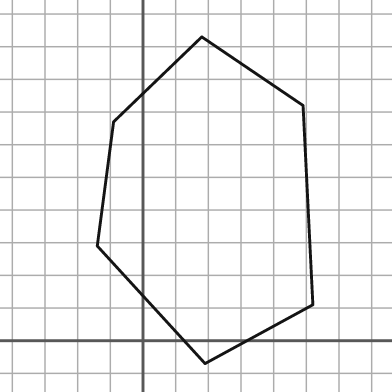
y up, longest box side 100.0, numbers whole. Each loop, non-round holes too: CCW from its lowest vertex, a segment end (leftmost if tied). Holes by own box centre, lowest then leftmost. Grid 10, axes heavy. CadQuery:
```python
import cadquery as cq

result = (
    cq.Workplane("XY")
    .moveTo(19.0, -7.0)
    .lineTo(52.0, 11.0)
    .lineTo(49.0, 72.0)
    .lineTo(18.0, 93.0)
    .lineTo(-9.0, 67.0)
    .lineTo(-14.0, 29.0)
    .close()
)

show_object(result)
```